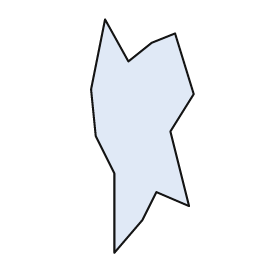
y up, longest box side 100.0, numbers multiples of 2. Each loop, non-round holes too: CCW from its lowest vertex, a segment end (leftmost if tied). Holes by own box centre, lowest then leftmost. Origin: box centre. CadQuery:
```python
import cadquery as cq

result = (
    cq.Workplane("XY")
    .moveTo(-12.0, -50.0)
    .lineTo(0.0, -36.0)
    .lineTo(6.0, -24.0)
    .lineTo(20.0, -30.0)
    .lineTo(12.0, 2.0)
    .lineTo(22.0, 18.0)
    .lineTo(14.0, 44.0)
    .lineTo(4.0, 40.0)
    .lineTo(-6.0, 32.0)
    .lineTo(-16.0, 50.0)
    .lineTo(-22.0, 20.0)
    .lineTo(-20.0, 0.0)
    .lineTo(-12.0, -16.0)
    .close()
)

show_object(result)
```